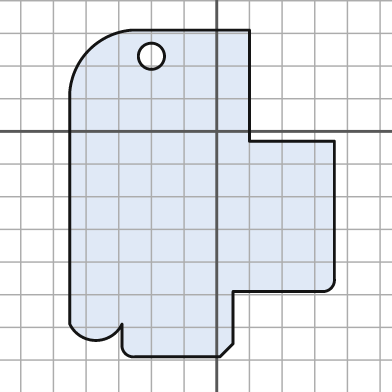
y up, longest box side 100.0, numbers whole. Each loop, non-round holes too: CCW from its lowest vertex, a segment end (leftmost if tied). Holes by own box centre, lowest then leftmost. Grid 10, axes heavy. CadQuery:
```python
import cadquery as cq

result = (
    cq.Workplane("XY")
    .moveTo(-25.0, -69.0)
    .lineTo(1.0, -69.0)
    .lineTo(5.0, -65.0)
    .lineTo(5.0, -49.0)
    .lineTo(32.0, -49.0)
    .threePointArc((35.0, -48.0), (36.0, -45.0))
    .lineTo(36.0, -3.0)
    .lineTo(10.0, -3.0)
    .lineTo(10.0, 31.0)
    .lineTo(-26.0, 31.0)
    .threePointArc((-39.0, 25.0), (-45.0, 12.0))
    .lineTo(-45.0, -59.0)
    .threePointArc((-37.0, -64.0), (-29.0, -59.0))
    .lineTo(-29.0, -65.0)
    .threePointArc((-28.0, -68.0), (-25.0, -69.0))
    .close()
    .moveTo(-20.0, 23.0)
    .circle(4.0)
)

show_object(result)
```